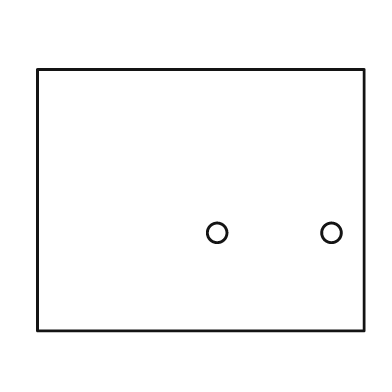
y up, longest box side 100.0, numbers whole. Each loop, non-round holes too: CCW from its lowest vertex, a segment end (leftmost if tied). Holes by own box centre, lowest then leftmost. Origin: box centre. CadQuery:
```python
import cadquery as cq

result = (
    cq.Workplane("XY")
    .moveTo(-50.0, -40.0)
    .lineTo(50.0, -40.0)
    .lineTo(50.0, 40.0)
    .lineTo(-50.0, 40.0)
    .close()
    .moveTo(5.0, -10.0)
    .circle(3.0)
    .moveTo(40.0, -10.0)
    .circle(3.0)
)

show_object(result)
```